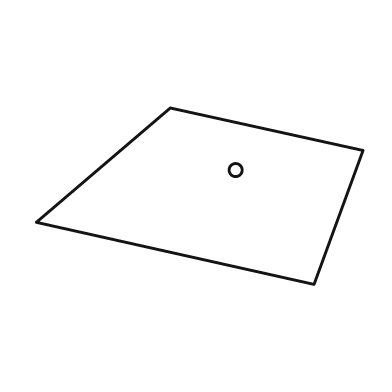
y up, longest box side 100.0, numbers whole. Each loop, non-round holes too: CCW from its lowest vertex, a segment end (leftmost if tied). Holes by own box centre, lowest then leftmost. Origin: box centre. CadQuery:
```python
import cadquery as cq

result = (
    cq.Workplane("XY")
    .moveTo(35.0, -27.0)
    .lineTo(50.0, 14.0)
    .lineTo(-9.0, 27.0)
    .lineTo(-50.0, -8.0)
    .close()
    .moveTo(11.0, 8.0)
    .circle(2.0)
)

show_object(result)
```